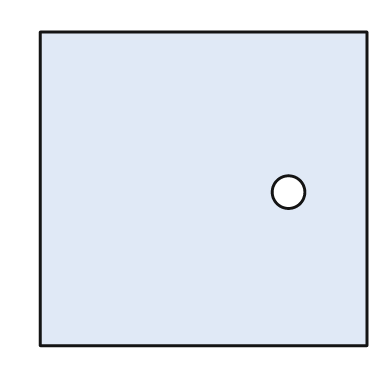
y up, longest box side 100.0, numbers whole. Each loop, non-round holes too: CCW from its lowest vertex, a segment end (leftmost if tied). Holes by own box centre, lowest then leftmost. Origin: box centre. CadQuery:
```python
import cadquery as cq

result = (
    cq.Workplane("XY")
    .moveTo(-50.0, -48.0)
    .lineTo(50.0, -48.0)
    .lineTo(50.0, 48.0)
    .lineTo(-50.0, 48.0)
    .close()
    .moveTo(26.0, -1.0)
    .circle(5.0)
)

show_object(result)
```